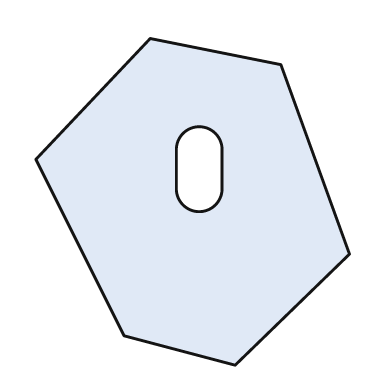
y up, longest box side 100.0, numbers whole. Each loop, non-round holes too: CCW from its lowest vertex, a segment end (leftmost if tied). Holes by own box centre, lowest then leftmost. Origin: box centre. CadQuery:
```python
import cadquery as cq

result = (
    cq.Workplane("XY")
    .moveTo(13.0, -50.0)
    .lineTo(48.0, -16.0)
    .lineTo(27.0, 42.0)
    .lineTo(-13.0, 50.0)
    .lineTo(-48.0, 13.0)
    .lineTo(-21.0, -41.0)
    .close()
    .moveTo(-5.0, 4.0)
    .threePointArc((2.0, -3.0), (9.0, 4.0))
    .lineTo(9.0, 16.0)
    .threePointArc((2.0, 23.0), (-5.0, 16.0))
    .close()
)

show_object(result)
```